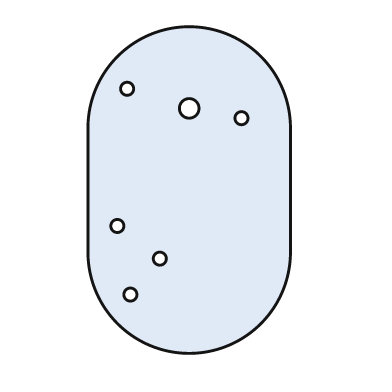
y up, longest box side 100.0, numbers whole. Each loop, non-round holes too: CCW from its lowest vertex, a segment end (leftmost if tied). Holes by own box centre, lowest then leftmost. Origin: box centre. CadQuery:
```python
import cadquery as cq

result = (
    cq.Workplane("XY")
    .moveTo(-31.0, -19.0)
    .threePointArc((0.0, -50.0), (31.0, -19.0))
    .lineTo(31.0, 19.0)
    .threePointArc((0.0, 50.0), (-31.0, 19.0))
    .close()
    .moveTo(-18.0, -32.0)
    .circle(2.0)
    .moveTo(-9.0, -21.0)
    .circle(2.0)
    .moveTo(-22.0, -11.0)
    .circle(2.0)
    .moveTo(16.0, 22.0)
    .circle(2.0)
    .moveTo(0.0, 25.0)
    .circle(3.0)
    .moveTo(-19.0, 31.0)
    .circle(2.0)
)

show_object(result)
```